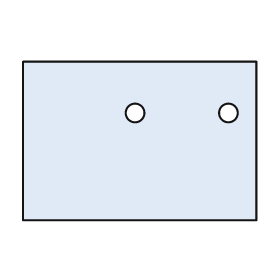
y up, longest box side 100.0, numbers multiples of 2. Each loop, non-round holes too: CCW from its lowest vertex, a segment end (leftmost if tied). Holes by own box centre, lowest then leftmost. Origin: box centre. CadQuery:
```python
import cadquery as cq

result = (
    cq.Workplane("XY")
    .moveTo(-50.0, -34.0)
    .lineTo(50.0, -34.0)
    .lineTo(50.0, 34.0)
    .lineTo(-50.0, 34.0)
    .close()
    .moveTo(-2.0, 12.0)
    .circle(4.0)
    .moveTo(38.0, 12.0)
    .circle(4.0)
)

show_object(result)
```